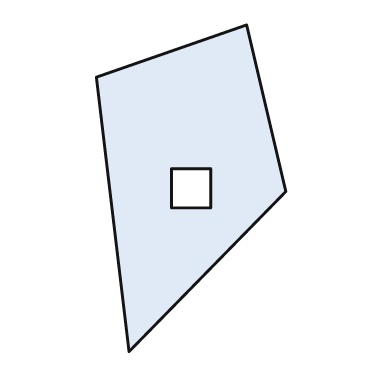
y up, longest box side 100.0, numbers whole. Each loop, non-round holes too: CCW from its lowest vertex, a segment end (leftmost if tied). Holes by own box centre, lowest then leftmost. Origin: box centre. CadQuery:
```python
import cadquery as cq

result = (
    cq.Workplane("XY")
    .moveTo(-19.0, -50.0)
    .lineTo(29.0, -1.0)
    .lineTo(17.0, 50.0)
    .lineTo(-29.0, 34.0)
    .close()
    .moveTo(-6.0, -6.0)
    .lineTo(6.0, -6.0)
    .lineTo(6.0, 6.0)
    .lineTo(-6.0, 6.0)
    .close()
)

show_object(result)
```